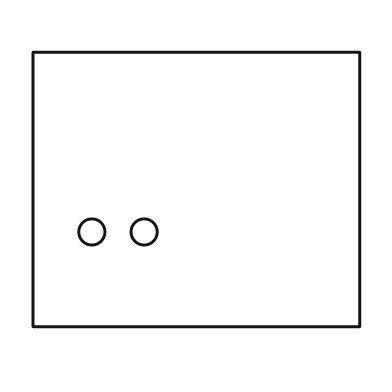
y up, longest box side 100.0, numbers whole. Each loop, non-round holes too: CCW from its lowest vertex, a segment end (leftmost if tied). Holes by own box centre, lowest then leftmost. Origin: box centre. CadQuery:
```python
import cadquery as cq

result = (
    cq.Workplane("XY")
    .moveTo(-50.0, -42.0)
    .lineTo(50.0, -42.0)
    .lineTo(50.0, 42.0)
    .lineTo(-50.0, 42.0)
    .close()
    .moveTo(-32.0, -13.0)
    .circle(4.0)
    .moveTo(-16.0, -13.0)
    .circle(4.0)
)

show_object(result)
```